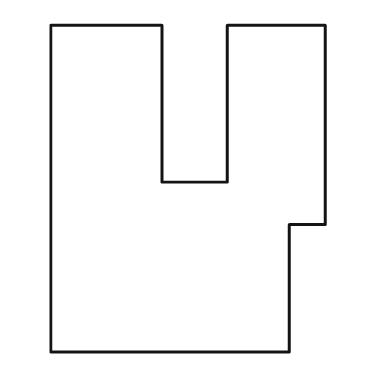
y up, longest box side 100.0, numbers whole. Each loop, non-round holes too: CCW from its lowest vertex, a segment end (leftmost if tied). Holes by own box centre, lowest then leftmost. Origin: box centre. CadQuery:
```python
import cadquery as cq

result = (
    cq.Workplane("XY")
    .moveTo(-42.0, -50.0)
    .lineTo(31.0, -50.0)
    .lineTo(31.0, -11.0)
    .lineTo(42.0, -11.0)
    .lineTo(42.0, 50.0)
    .lineTo(12.0, 50.0)
    .lineTo(12.0, 2.0)
    .lineTo(-8.0, 2.0)
    .lineTo(-8.0, 50.0)
    .lineTo(-42.0, 50.0)
    .close()
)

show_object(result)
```